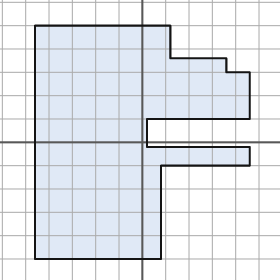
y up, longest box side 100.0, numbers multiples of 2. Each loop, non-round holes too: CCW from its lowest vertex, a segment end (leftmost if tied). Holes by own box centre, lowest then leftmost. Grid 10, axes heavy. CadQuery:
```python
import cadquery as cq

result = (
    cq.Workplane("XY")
    .moveTo(-46.0, -50.0)
    .lineTo(8.0, -50.0)
    .lineTo(8.0, -10.0)
    .lineTo(46.0, -10.0)
    .lineTo(46.0, -2.0)
    .lineTo(2.0, -2.0)
    .lineTo(2.0, 10.0)
    .lineTo(46.0, 10.0)
    .lineTo(46.0, 30.0)
    .lineTo(36.0, 30.0)
    .lineTo(36.0, 36.0)
    .lineTo(12.0, 36.0)
    .lineTo(12.0, 50.0)
    .lineTo(-46.0, 50.0)
    .close()
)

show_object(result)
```